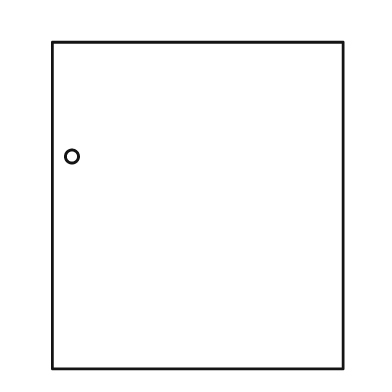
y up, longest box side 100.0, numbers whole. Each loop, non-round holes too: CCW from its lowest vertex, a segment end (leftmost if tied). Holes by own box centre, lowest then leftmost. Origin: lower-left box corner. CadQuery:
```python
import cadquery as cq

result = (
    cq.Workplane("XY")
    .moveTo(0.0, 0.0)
    .lineTo(89.0, 0.0)
    .lineTo(89.0, 100.0)
    .lineTo(0.0, 100.0)
    .close()
    .moveTo(6.0, 65.0)
    .circle(2.0)
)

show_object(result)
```